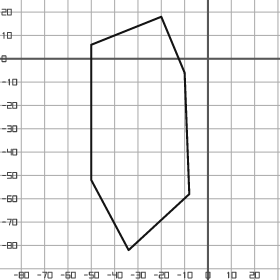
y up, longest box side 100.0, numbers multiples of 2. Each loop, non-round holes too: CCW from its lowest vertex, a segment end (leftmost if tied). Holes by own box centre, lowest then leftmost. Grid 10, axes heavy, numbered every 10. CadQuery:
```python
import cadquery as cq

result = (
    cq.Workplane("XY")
    .moveTo(-34.0, -82.0)
    .lineTo(-8.0, -58.0)
    .lineTo(-10.0, -6.0)
    .lineTo(-20.0, 18.0)
    .lineTo(-50.0, 6.0)
    .lineTo(-50.0, -52.0)
    .close()
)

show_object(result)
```